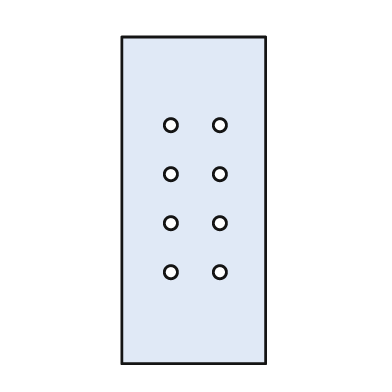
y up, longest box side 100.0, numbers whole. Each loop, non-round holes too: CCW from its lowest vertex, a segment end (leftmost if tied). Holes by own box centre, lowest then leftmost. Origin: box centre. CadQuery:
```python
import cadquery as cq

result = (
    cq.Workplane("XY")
    .moveTo(-22.0, -50.0)
    .lineTo(22.0, -50.0)
    .lineTo(22.0, 50.0)
    .lineTo(-22.0, 50.0)
    .close()
    .moveTo(-7.0, -22.0)
    .circle(2.0)
    .moveTo(8.0, -22.0)
    .circle(2.0)
    .moveTo(-7.0, -7.0)
    .circle(2.0)
    .moveTo(8.0, -7.0)
    .circle(2.0)
    .moveTo(-7.0, 8.0)
    .circle(2.0)
    .moveTo(8.0, 8.0)
    .circle(2.0)
    .moveTo(-7.0, 23.0)
    .circle(2.0)
    .moveTo(8.0, 23.0)
    .circle(2.0)
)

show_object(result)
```